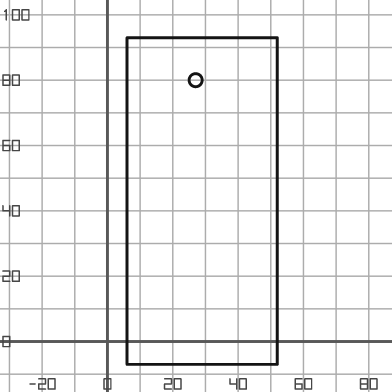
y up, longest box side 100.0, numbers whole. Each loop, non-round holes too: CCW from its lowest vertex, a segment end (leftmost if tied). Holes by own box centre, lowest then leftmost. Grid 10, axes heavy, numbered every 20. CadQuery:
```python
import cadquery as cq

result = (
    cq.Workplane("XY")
    .moveTo(6.0, -7.0)
    .lineTo(52.0, -7.0)
    .lineTo(52.0, 93.0)
    .lineTo(6.0, 93.0)
    .close()
    .moveTo(27.0, 80.0)
    .circle(2.0)
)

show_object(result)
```